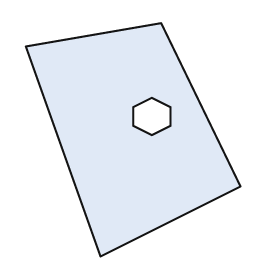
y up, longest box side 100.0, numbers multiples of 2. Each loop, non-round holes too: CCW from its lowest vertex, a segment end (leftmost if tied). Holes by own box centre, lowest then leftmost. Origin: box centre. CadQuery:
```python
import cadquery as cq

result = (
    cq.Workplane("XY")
    .moveTo(-14.0, -50.0)
    .lineTo(46.0, -20.0)
    .lineTo(12.0, 50.0)
    .lineTo(-46.0, 40.0)
    .close()
    .moveTo(8.0, 2.0)
    .lineTo(16.0, 6.0)
    .lineTo(16.0, 14.0)
    .lineTo(8.0, 18.0)
    .lineTo(0.0, 14.0)
    .lineTo(0.0, 6.0)
    .close()
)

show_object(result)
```